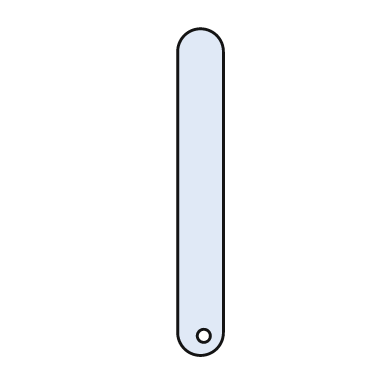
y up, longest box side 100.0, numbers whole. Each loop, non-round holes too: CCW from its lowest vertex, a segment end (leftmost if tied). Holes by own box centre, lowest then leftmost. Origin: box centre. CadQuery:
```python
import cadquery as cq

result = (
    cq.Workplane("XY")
    .moveTo(-7.0, -43.0)
    .threePointArc((0.0, -50.0), (7.0, -43.0))
    .lineTo(7.0, 43.0)
    .threePointArc((0.0, 50.0), (-7.0, 43.0))
    .close()
    .moveTo(1.0, -44.0)
    .circle(2.0)
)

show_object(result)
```